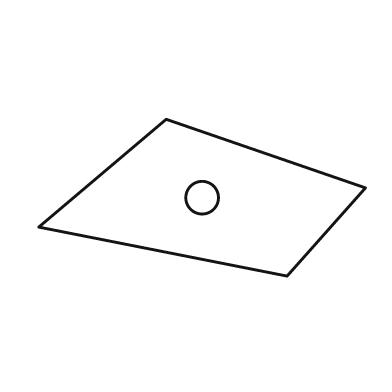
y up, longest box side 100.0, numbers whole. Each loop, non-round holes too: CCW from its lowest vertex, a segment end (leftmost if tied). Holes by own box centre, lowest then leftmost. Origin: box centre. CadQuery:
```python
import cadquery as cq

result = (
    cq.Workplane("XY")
    .moveTo(26.0, -24.0)
    .lineTo(50.0, 3.0)
    .lineTo(-11.0, 24.0)
    .lineTo(-50.0, -9.0)
    .close()
    .moveTo(0.0, 0.0)
    .circle(5.0)
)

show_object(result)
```